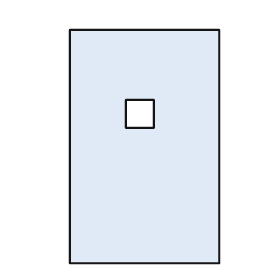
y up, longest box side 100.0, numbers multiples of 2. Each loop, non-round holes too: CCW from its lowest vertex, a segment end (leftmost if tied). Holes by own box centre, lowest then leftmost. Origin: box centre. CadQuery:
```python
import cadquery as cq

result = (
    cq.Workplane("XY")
    .moveTo(-32.0, -50.0)
    .lineTo(32.0, -50.0)
    .lineTo(32.0, 50.0)
    .lineTo(-32.0, 50.0)
    .close()
    .moveTo(-8.0, 8.0)
    .lineTo(4.0, 8.0)
    .lineTo(4.0, 20.0)
    .lineTo(-8.0, 20.0)
    .close()
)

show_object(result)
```